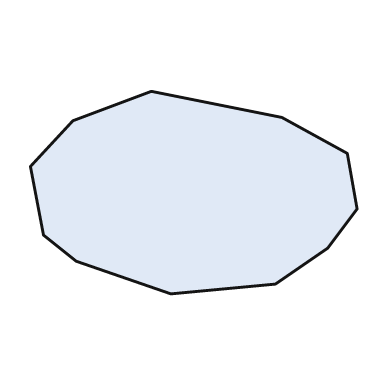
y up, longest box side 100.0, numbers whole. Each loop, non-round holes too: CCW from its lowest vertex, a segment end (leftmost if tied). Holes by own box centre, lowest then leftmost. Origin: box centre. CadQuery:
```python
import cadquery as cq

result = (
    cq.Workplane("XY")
    .moveTo(-7.0, -31.0)
    .lineTo(25.0, -28.0)
    .lineTo(41.0, -17.0)
    .lineTo(50.0, -5.0)
    .lineTo(47.0, 12.0)
    .lineTo(27.0, 23.0)
    .lineTo(-13.0, 31.0)
    .lineTo(-37.0, 22.0)
    .lineTo(-50.0, 8.0)
    .lineTo(-46.0, -13.0)
    .lineTo(-36.0, -21.0)
    .close()
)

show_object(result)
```